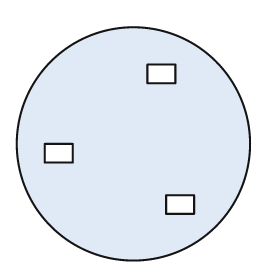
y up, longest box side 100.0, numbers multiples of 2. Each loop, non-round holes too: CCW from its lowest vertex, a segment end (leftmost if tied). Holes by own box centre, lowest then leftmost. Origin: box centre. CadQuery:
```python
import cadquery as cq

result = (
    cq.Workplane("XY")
    .moveTo(0.0, 0.0)
    .circle(50.0)
    .moveTo(14.0, -30.0)
    .lineTo(26.0, -30.0)
    .lineTo(26.0, -22.0)
    .lineTo(14.0, -22.0)
    .close()
    .moveTo(-38.0, -8.0)
    .lineTo(-26.0, -8.0)
    .lineTo(-26.0, 0.0)
    .lineTo(-38.0, 0.0)
    .close()
    .moveTo(6.0, 26.0)
    .lineTo(18.0, 26.0)
    .lineTo(18.0, 34.0)
    .lineTo(6.0, 34.0)
    .close()
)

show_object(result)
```